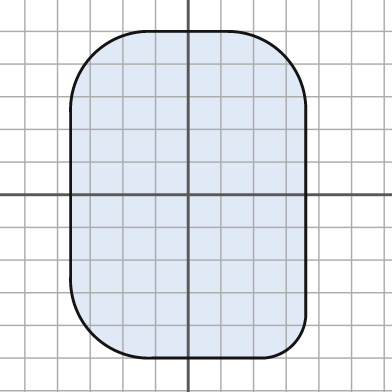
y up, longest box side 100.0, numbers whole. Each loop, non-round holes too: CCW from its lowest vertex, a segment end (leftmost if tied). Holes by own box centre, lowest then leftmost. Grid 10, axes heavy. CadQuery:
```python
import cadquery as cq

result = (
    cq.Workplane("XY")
    .moveTo(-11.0, -50.0)
    .lineTo(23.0, -50.0)
    .threePointArc((32.0, -46.0), (36.0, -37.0))
    .lineTo(36.0, 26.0)
    .threePointArc((29.0, 43.0), (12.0, 50.0))
    .lineTo(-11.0, 50.0)
    .threePointArc((-29.0, 43.0), (-36.0, 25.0))
    .lineTo(-36.0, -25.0)
    .threePointArc((-29.0, -43.0), (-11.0, -50.0))
    .close()
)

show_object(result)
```